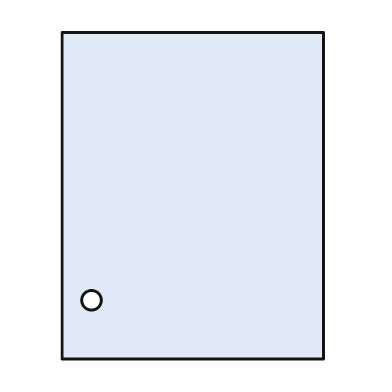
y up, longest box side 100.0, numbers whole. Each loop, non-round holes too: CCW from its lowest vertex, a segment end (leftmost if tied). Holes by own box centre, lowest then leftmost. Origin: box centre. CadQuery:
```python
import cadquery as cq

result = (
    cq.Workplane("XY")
    .moveTo(-40.0, -50.0)
    .lineTo(40.0, -50.0)
    .lineTo(40.0, 50.0)
    .lineTo(-40.0, 50.0)
    .close()
    .moveTo(-31.0, -32.0)
    .circle(3.0)
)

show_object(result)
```